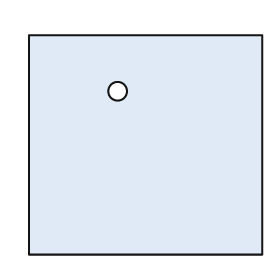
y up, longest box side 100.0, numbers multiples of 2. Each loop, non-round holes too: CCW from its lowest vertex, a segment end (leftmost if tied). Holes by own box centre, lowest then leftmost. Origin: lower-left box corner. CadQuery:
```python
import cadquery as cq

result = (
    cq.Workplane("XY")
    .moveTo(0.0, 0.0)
    .lineTo(100.0, 0.0)
    .lineTo(100.0, 94.0)
    .lineTo(0.0, 94.0)
    .close()
    .moveTo(38.0, 70.0)
    .circle(4.0)
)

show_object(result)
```